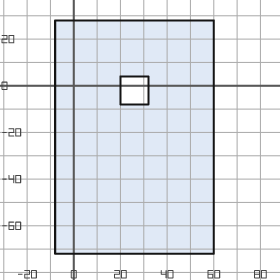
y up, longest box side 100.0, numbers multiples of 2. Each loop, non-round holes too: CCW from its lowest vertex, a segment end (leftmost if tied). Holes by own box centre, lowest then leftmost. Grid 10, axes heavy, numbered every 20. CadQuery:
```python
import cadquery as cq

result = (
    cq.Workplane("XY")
    .moveTo(-8.0, -72.0)
    .lineTo(60.0, -72.0)
    .lineTo(60.0, 28.0)
    .lineTo(-8.0, 28.0)
    .close()
    .moveTo(20.0, -8.0)
    .lineTo(32.0, -8.0)
    .lineTo(32.0, 4.0)
    .lineTo(20.0, 4.0)
    .close()
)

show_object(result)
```